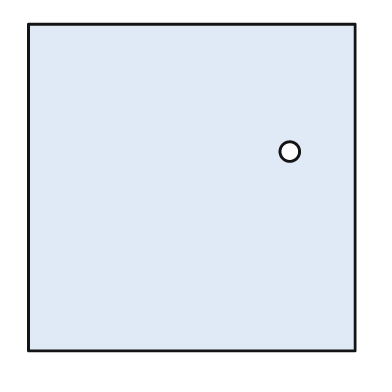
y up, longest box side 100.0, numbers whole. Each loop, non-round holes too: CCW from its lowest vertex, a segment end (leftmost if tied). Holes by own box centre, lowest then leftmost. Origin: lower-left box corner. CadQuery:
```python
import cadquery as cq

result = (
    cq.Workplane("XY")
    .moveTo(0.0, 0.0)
    .lineTo(100.0, 0.0)
    .lineTo(100.0, 100.0)
    .lineTo(0.0, 100.0)
    .close()
    .moveTo(80.0, 61.0)
    .circle(3.0)
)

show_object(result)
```